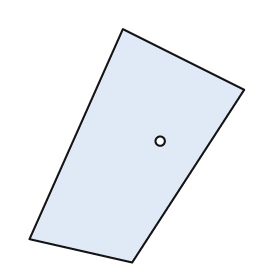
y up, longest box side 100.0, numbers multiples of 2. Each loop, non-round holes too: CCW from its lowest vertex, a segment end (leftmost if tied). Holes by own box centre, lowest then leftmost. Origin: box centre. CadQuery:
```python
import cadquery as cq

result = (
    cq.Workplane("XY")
    .moveTo(-2.0, -50.0)
    .lineTo(46.0, 24.0)
    .lineTo(-6.0, 50.0)
    .lineTo(-46.0, -40.0)
    .close()
    .moveTo(10.0, 2.0)
    .circle(2.0)
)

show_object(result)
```